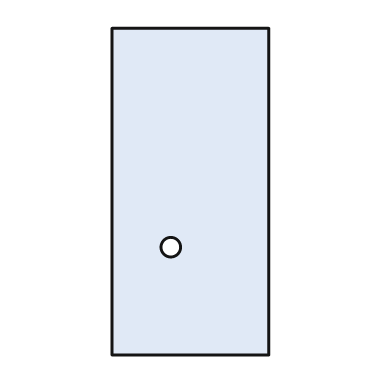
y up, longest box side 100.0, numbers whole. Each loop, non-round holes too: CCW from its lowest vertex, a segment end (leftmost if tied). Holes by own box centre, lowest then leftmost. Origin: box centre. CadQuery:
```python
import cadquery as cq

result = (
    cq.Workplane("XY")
    .moveTo(-24.0, -50.0)
    .lineTo(24.0, -50.0)
    .lineTo(24.0, 50.0)
    .lineTo(-24.0, 50.0)
    .close()
    .moveTo(-6.0, -17.0)
    .circle(3.0)
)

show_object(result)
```